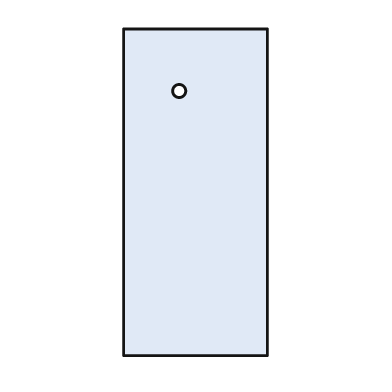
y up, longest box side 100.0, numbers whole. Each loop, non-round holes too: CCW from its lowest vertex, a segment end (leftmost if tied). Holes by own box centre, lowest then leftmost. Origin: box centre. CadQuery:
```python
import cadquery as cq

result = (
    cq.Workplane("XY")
    .moveTo(-22.0, -50.0)
    .lineTo(22.0, -50.0)
    .lineTo(22.0, 50.0)
    .lineTo(-22.0, 50.0)
    .close()
    .moveTo(-5.0, 31.0)
    .circle(2.0)
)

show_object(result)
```